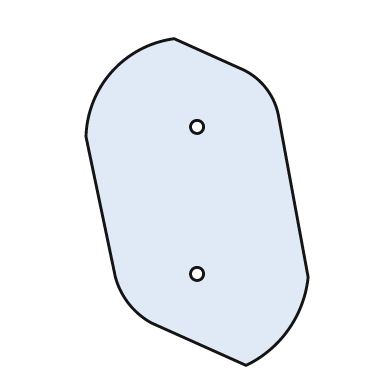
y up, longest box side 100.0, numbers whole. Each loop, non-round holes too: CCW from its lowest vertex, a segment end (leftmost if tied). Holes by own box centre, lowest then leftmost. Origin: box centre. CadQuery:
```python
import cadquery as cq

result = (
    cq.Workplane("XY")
    .moveTo(15.0, -50.0)
    .threePointArc((28.0, -39.0), (34.0, -23.0))
    .lineTo(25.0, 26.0)
    .threePointArc((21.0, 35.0), (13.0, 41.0))
    .lineTo(-7.0, 50.0)
    .threePointArc((-26.0, 40.0), (-34.0, 20.0))
    .lineTo(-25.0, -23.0)
    .threePointArc((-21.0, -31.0), (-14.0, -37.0))
    .close()
    .moveTo(0.0, -22.0)
    .circle(2.0)
    .moveTo(0.0, 23.0)
    .circle(2.0)
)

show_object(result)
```